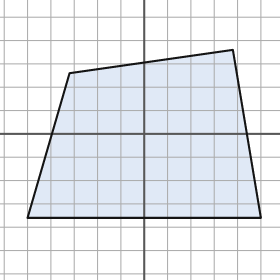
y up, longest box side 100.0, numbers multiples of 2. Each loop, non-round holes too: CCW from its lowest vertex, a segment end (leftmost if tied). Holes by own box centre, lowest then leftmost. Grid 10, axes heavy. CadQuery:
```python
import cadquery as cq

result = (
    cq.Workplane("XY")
    .moveTo(-50.0, -36.0)
    .lineTo(50.0, -36.0)
    .lineTo(38.0, 36.0)
    .lineTo(-32.0, 26.0)
    .close()
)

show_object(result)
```